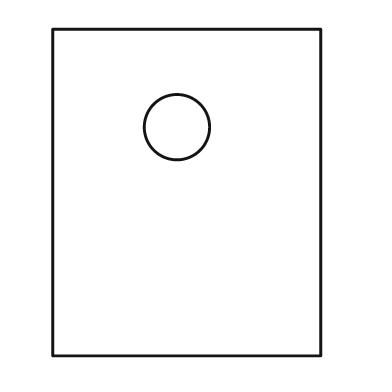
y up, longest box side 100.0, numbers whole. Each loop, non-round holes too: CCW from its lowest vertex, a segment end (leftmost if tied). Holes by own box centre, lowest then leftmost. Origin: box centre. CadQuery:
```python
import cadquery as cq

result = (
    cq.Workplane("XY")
    .moveTo(-41.0, -50.0)
    .lineTo(41.0, -50.0)
    .lineTo(41.0, 50.0)
    .lineTo(-41.0, 50.0)
    .close()
    .moveTo(-3.0, 20.0)
    .circle(10.0)
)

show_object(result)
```